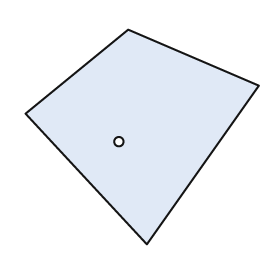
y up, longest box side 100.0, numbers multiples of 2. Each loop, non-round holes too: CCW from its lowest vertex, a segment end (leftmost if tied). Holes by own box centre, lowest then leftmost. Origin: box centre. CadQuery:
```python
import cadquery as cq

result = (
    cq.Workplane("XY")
    .moveTo(2.0, -46.0)
    .lineTo(50.0, 22.0)
    .lineTo(-6.0, 46.0)
    .lineTo(-50.0, 10.0)
    .close()
    .moveTo(-10.0, -2.0)
    .circle(2.0)
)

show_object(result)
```